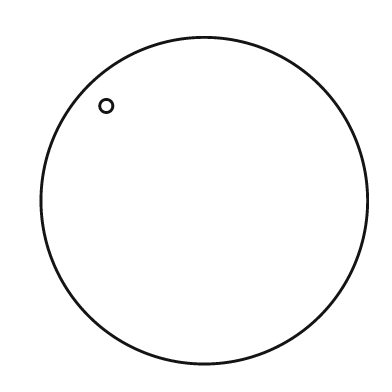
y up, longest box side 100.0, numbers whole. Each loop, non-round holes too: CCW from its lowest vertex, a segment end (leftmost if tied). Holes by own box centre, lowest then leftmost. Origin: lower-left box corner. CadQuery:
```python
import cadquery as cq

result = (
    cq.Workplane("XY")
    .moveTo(50.0, 50.0)
    .circle(50.0)
    .moveTo(20.0, 79.0)
    .circle(2.0)
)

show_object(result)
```